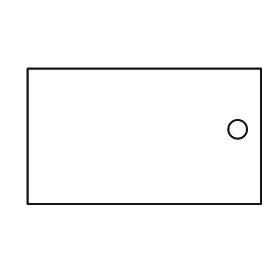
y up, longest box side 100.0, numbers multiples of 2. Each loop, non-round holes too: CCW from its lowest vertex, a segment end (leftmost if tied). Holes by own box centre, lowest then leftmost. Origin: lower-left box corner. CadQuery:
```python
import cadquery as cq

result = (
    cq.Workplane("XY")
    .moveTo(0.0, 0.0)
    .lineTo(100.0, 0.0)
    .lineTo(100.0, 58.0)
    .lineTo(0.0, 58.0)
    .close()
    .moveTo(90.0, 32.0)
    .circle(4.0)
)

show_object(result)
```